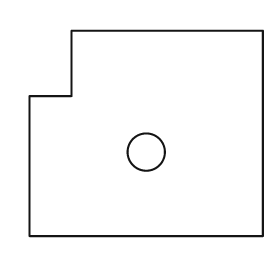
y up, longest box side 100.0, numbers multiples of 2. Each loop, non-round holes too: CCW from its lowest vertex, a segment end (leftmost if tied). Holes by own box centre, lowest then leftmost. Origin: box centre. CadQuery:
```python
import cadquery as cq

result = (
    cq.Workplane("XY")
    .moveTo(-50.0, -44.0)
    .lineTo(50.0, -44.0)
    .lineTo(50.0, 44.0)
    .lineTo(-32.0, 44.0)
    .lineTo(-32.0, 16.0)
    .lineTo(-50.0, 16.0)
    .close()
    .moveTo(0.0, -8.0)
    .circle(8.0)
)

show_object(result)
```